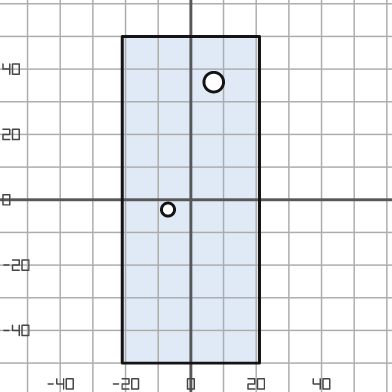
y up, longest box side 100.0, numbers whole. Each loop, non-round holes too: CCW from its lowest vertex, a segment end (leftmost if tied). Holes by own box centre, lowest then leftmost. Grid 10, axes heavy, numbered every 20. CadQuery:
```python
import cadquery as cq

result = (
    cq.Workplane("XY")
    .moveTo(-21.0, -50.0)
    .lineTo(21.0, -50.0)
    .lineTo(21.0, 50.0)
    .lineTo(-21.0, 50.0)
    .close()
    .moveTo(-7.0, -3.0)
    .circle(2.0)
    .moveTo(7.0, 36.0)
    .circle(3.0)
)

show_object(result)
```